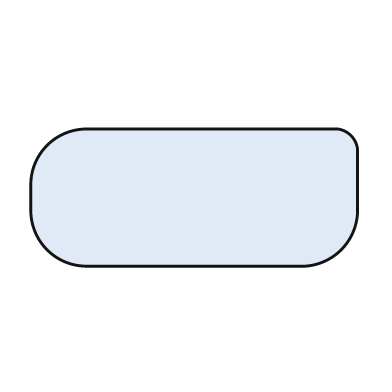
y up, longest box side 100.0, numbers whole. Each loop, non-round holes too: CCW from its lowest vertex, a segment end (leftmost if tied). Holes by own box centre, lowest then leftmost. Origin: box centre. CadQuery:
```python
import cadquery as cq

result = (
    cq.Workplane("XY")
    .moveTo(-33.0, -21.0)
    .lineTo(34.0, -21.0)
    .threePointArc((45.0, -16.0), (50.0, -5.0))
    .lineTo(50.0, 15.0)
    .threePointArc((48.0, 19.0), (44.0, 21.0))
    .lineTo(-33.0, 21.0)
    .threePointArc((-45.0, 16.0), (-50.0, 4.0))
    .lineTo(-50.0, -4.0)
    .threePointArc((-45.0, -16.0), (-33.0, -21.0))
    .close()
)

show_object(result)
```